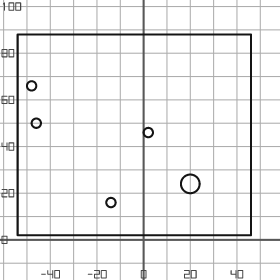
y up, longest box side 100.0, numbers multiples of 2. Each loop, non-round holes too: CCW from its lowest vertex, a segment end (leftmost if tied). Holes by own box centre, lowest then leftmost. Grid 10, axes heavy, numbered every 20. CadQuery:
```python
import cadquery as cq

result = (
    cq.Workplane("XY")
    .moveTo(-54.0, 2.0)
    .lineTo(46.0, 2.0)
    .lineTo(46.0, 88.0)
    .lineTo(-54.0, 88.0)
    .close()
    .moveTo(-14.0, 16.0)
    .circle(2.0)
    .moveTo(20.0, 24.0)
    .circle(4.0)
    .moveTo(2.0, 46.0)
    .circle(2.0)
    .moveTo(-46.0, 50.0)
    .circle(2.0)
    .moveTo(-48.0, 66.0)
    .circle(2.0)
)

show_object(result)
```